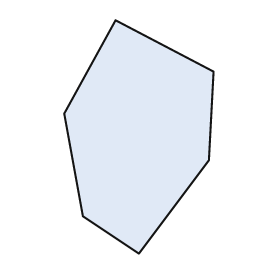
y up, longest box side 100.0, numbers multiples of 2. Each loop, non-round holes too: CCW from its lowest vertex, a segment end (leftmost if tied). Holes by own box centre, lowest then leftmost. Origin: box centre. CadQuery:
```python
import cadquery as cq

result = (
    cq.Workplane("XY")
    .moveTo(0.0, -50.0)
    .lineTo(30.0, -10.0)
    .lineTo(32.0, 28.0)
    .lineTo(-10.0, 50.0)
    .lineTo(-32.0, 10.0)
    .lineTo(-24.0, -34.0)
    .close()
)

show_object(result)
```